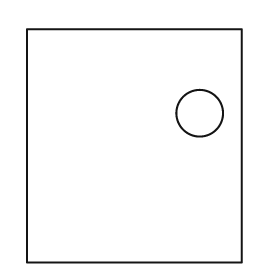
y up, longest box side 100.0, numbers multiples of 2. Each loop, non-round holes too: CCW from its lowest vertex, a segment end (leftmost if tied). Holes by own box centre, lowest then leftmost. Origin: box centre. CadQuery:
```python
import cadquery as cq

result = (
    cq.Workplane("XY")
    .moveTo(-46.0, -50.0)
    .lineTo(46.0, -50.0)
    .lineTo(46.0, 50.0)
    .lineTo(-46.0, 50.0)
    .close()
    .moveTo(28.0, 14.0)
    .circle(10.0)
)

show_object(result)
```